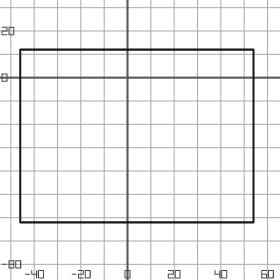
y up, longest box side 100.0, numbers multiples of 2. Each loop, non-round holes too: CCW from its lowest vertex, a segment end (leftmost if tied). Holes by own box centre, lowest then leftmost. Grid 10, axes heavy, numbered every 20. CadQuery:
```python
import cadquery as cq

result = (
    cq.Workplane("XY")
    .moveTo(-46.0, -62.0)
    .lineTo(54.0, -62.0)
    .lineTo(54.0, 12.0)
    .lineTo(-46.0, 12.0)
    .close()
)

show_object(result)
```